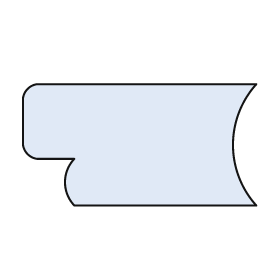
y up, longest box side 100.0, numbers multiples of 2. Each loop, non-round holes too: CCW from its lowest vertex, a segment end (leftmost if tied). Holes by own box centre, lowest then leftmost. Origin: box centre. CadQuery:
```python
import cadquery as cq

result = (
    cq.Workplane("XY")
    .moveTo(-28.0, -26.0)
    .lineTo(50.0, -26.0)
    .threePointArc((40.0, 0.0), (50.0, 26.0))
    .lineTo(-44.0, 26.0)
    .threePointArc((-48.0, 24.0), (-50.0, 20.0))
    .lineTo(-50.0, 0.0)
    .threePointArc((-48.0, -4.0), (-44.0, -6.0))
    .lineTo(-28.0, -6.0)
    .threePointArc((-32.0, -16.0), (-28.0, -26.0))
    .close()
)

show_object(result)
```